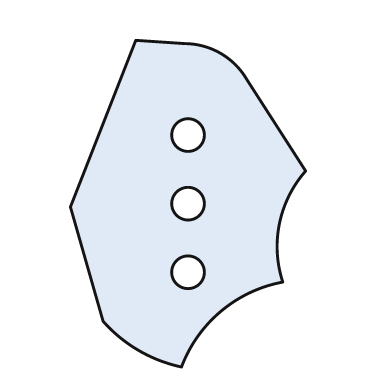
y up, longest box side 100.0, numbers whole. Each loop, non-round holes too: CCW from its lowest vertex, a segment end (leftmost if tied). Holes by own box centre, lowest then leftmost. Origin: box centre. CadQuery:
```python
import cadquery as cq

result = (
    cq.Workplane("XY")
    .moveTo(-2.0, -50.0)
    .threePointArc((10.0, -33.0), (29.0, -24.0))
    .threePointArc((28.0, -6.0), (36.0, 10.0))
    .lineTo(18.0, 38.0)
    .threePointArc((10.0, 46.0), (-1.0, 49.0))
    .lineTo(-16.0, 50.0)
    .lineTo(-36.0, -1.0)
    .lineTo(-26.0, -36.0)
    .threePointArc((-15.0, -45.0), (-2.0, -50.0))
    .close()
    .moveTo(0.0, -21.0)
    .circle(5.0)
    .moveTo(0.0, 0.0)
    .circle(5.0)
    .moveTo(0.0, 21.0)
    .circle(5.0)
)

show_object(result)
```